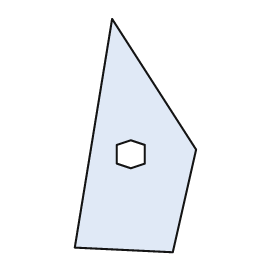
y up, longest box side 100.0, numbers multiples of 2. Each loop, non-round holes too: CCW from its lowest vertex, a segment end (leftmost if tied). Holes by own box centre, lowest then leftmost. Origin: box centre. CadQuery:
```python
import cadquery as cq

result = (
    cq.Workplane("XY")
    .moveTo(16.0, -50.0)
    .lineTo(26.0, -6.0)
    .lineTo(-10.0, 50.0)
    .lineTo(-26.0, -48.0)
    .close()
    .moveTo(-2.0, -14.0)
    .lineTo(4.0, -12.0)
    .lineTo(4.0, -4.0)
    .lineTo(-2.0, -2.0)
    .lineTo(-8.0, -4.0)
    .lineTo(-8.0, -12.0)
    .close()
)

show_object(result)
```